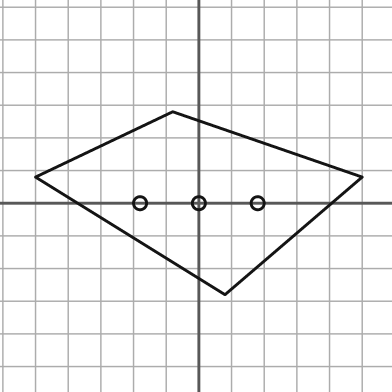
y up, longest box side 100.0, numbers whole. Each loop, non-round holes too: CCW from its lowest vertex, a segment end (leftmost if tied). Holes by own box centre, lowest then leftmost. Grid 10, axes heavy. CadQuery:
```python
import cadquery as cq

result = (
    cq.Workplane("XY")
    .moveTo(8.0, -28.0)
    .lineTo(50.0, 8.0)
    .lineTo(-8.0, 28.0)
    .lineTo(-50.0, 8.0)
    .close()
    .moveTo(-18.0, 0.0)
    .circle(2.0)
    .moveTo(0.0, 0.0)
    .circle(2.0)
    .moveTo(18.0, 0.0)
    .circle(2.0)
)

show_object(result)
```